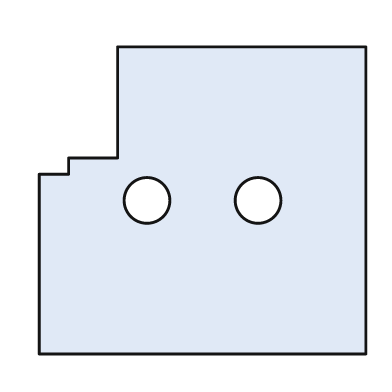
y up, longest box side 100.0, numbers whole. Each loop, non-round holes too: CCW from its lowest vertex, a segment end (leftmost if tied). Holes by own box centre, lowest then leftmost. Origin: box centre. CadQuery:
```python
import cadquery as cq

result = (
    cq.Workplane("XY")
    .moveTo(-50.0, -47.0)
    .lineTo(50.0, -47.0)
    .lineTo(50.0, 47.0)
    .lineTo(-26.0, 47.0)
    .lineTo(-26.0, 13.0)
    .lineTo(-41.0, 13.0)
    .lineTo(-41.0, 8.0)
    .lineTo(-50.0, 8.0)
    .close()
    .moveTo(-17.0, 0.0)
    .circle(7.0)
    .moveTo(17.0, 0.0)
    .circle(7.0)
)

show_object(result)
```